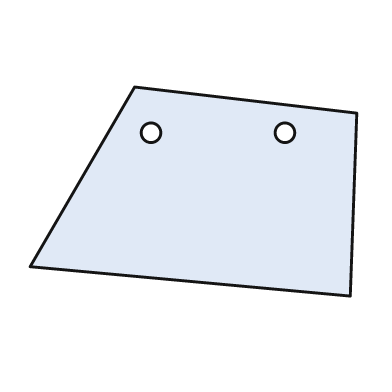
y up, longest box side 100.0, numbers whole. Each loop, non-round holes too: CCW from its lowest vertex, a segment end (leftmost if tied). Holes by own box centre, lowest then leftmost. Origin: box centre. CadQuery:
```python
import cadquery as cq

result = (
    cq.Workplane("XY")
    .moveTo(48.0, -32.0)
    .lineTo(50.0, 24.0)
    .lineTo(-18.0, 32.0)
    .lineTo(-50.0, -23.0)
    .close()
    .moveTo(-13.0, 18.0)
    .circle(3.0)
    .moveTo(28.0, 18.0)
    .circle(3.0)
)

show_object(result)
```